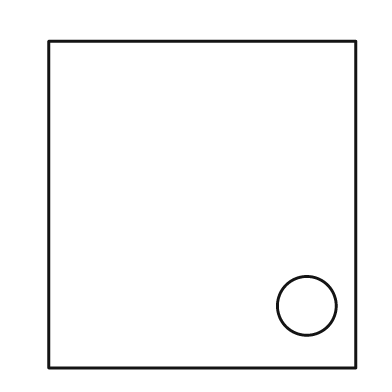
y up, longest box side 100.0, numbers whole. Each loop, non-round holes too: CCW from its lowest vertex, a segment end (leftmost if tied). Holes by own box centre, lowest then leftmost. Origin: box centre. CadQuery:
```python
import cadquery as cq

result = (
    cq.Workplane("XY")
    .moveTo(-47.0, -50.0)
    .lineTo(47.0, -50.0)
    .lineTo(47.0, 50.0)
    .lineTo(-47.0, 50.0)
    .close()
    .moveTo(32.0, -31.0)
    .circle(9.0)
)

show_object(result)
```